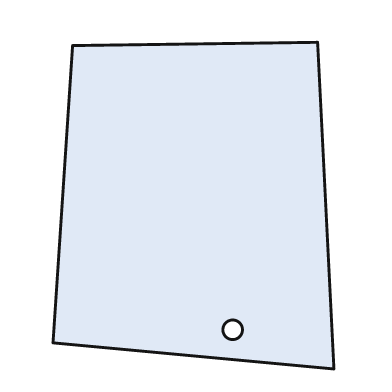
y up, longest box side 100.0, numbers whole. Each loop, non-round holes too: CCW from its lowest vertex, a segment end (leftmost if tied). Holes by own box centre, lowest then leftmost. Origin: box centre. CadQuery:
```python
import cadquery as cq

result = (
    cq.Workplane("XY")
    .moveTo(43.0, -50.0)
    .lineTo(38.0, 50.0)
    .lineTo(-37.0, 49.0)
    .lineTo(-43.0, -42.0)
    .close()
    .moveTo(12.0, -38.0)
    .circle(3.0)
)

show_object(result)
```